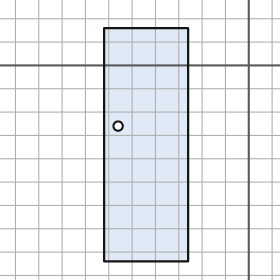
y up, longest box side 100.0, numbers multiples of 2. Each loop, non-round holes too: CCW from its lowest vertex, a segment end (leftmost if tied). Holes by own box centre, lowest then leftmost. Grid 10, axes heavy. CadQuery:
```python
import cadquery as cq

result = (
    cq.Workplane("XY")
    .moveTo(-62.0, -84.0)
    .lineTo(-26.0, -84.0)
    .lineTo(-26.0, 16.0)
    .lineTo(-62.0, 16.0)
    .close()
    .moveTo(-56.0, -26.0)
    .circle(2.0)
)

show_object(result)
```